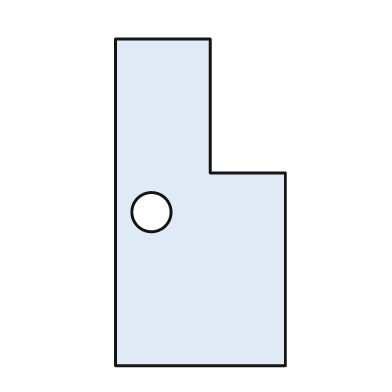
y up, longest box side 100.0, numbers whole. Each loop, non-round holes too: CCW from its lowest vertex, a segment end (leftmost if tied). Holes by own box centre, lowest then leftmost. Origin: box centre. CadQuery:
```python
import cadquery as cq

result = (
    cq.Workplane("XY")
    .moveTo(-26.0, -50.0)
    .lineTo(26.0, -50.0)
    .lineTo(26.0, 9.0)
    .lineTo(3.0, 9.0)
    .lineTo(3.0, 50.0)
    .lineTo(-26.0, 50.0)
    .close()
    .moveTo(-15.0, -3.0)
    .circle(6.0)
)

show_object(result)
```